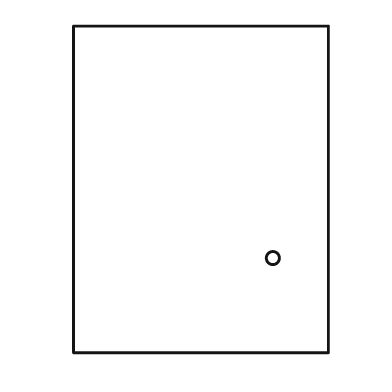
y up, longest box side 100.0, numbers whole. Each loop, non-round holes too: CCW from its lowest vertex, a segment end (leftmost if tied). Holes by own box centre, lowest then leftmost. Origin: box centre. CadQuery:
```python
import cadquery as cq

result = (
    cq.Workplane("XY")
    .moveTo(-39.0, -50.0)
    .lineTo(39.0, -50.0)
    .lineTo(39.0, 50.0)
    .lineTo(-39.0, 50.0)
    .close()
    .moveTo(22.0, -21.0)
    .circle(2.0)
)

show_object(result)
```